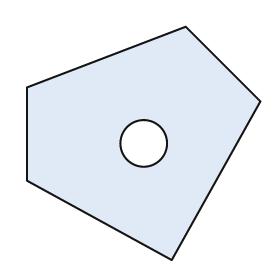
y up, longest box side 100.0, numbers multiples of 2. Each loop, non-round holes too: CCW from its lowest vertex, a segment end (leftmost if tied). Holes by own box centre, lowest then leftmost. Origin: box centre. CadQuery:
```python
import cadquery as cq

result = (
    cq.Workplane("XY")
    .moveTo(12.0, -50.0)
    .lineTo(50.0, 18.0)
    .lineTo(18.0, 50.0)
    .lineTo(-50.0, 24.0)
    .lineTo(-50.0, -16.0)
    .close()
    .moveTo(0.0, 0.0)
    .circle(10.0)
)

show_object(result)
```